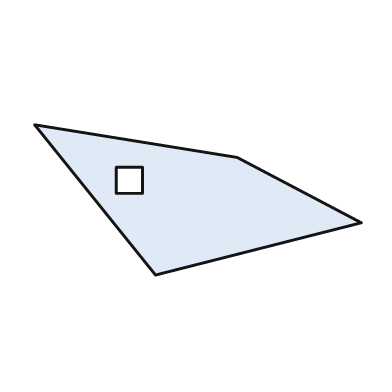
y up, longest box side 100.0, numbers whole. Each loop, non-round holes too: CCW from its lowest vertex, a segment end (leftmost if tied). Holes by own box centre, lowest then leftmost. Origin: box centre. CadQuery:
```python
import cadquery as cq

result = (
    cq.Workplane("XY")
    .moveTo(-13.0, -23.0)
    .lineTo(50.0, -7.0)
    .lineTo(12.0, 13.0)
    .lineTo(-50.0, 23.0)
    .close()
    .moveTo(-25.0, 2.0)
    .lineTo(-17.0, 2.0)
    .lineTo(-17.0, 10.0)
    .lineTo(-25.0, 10.0)
    .close()
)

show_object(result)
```